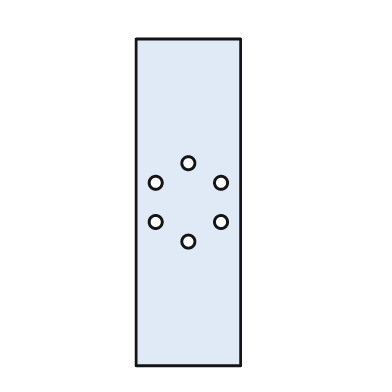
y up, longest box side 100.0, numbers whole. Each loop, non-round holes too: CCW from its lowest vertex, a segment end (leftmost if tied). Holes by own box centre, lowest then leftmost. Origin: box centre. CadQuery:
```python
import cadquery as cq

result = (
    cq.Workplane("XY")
    .moveTo(-16.0, -50.0)
    .lineTo(16.0, -50.0)
    .lineTo(16.0, 50.0)
    .lineTo(-16.0, 50.0)
    .close()
    .moveTo(0.0, -12.0)
    .circle(2.0)
    .moveTo(-10.0, -6.0)
    .circle(2.0)
    .moveTo(10.0, -6.0)
    .circle(2.0)
    .moveTo(-10.0, 6.0)
    .circle(2.0)
    .moveTo(10.0, 6.0)
    .circle(2.0)
    .moveTo(0.0, 12.0)
    .circle(2.0)
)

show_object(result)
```